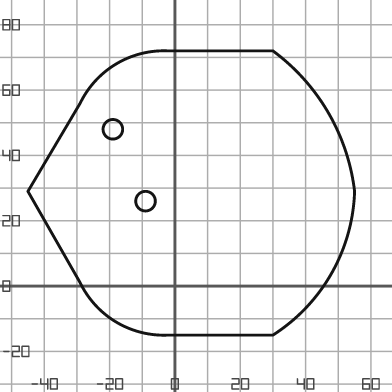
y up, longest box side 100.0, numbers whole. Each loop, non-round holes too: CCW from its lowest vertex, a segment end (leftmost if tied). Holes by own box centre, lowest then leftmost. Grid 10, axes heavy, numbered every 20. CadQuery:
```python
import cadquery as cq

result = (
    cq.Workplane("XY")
    .moveTo(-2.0, -15.0)
    .lineTo(30.0, -15.0)
    .threePointArc((48.0, 4.0), (55.0, 29.0))
    .threePointArc((47.0, 53.0), (30.0, 72.0))
    .lineTo(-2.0, 72.0)
    .threePointArc((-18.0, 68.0), (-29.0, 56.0))
    .lineTo(-45.0, 29.0)
    .lineTo(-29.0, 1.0)
    .threePointArc((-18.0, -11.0), (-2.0, -15.0))
    .close()
    .moveTo(-9.0, 26.0)
    .circle(3.0)
    .moveTo(-19.0, 48.0)
    .circle(3.0)
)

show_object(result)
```